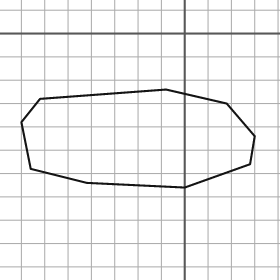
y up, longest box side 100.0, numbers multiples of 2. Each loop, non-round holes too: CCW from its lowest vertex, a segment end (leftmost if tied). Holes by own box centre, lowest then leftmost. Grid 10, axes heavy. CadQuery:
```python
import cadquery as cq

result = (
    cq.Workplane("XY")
    .moveTo(0.0, -66.0)
    .lineTo(28.0, -56.0)
    .lineTo(30.0, -44.0)
    .lineTo(18.0, -30.0)
    .lineTo(-8.0, -24.0)
    .lineTo(-62.0, -28.0)
    .lineTo(-70.0, -38.0)
    .lineTo(-66.0, -58.0)
    .lineTo(-42.0, -64.0)
    .close()
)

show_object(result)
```